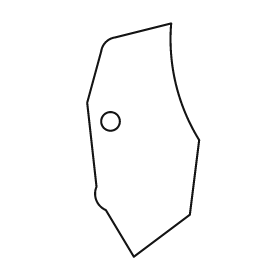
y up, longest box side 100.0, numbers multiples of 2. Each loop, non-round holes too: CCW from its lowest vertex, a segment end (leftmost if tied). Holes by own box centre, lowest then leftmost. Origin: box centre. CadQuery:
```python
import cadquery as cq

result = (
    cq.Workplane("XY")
    .moveTo(-4.0, -50.0)
    .lineTo(20.0, -32.0)
    .lineTo(24.0, 0.0)
    .threePointArc((14.0, 24.0), (12.0, 50.0))
    .lineTo(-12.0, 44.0)
    .threePointArc((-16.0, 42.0), (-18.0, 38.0))
    .lineTo(-24.0, 16.0)
    .lineTo(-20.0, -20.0)
    .threePointArc((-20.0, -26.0), (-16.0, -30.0))
    .close()
    .moveTo(-14.0, 8.0)
    .circle(4.0)
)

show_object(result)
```